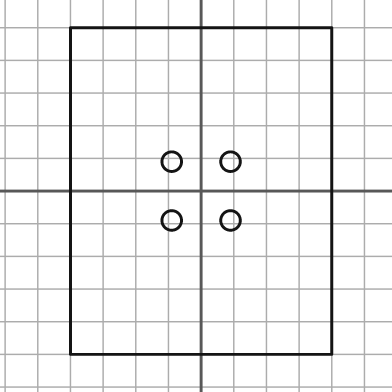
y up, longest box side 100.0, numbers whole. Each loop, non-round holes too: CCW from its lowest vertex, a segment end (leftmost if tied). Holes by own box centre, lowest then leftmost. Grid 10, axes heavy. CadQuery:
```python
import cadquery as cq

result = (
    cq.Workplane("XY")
    .moveTo(-40.0, -50.0)
    .lineTo(40.0, -50.0)
    .lineTo(40.0, 50.0)
    .lineTo(-40.0, 50.0)
    .close()
    .moveTo(-9.0, -9.0)
    .circle(3.0)
    .moveTo(9.0, -9.0)
    .circle(3.0)
    .moveTo(-9.0, 9.0)
    .circle(3.0)
    .moveTo(9.0, 9.0)
    .circle(3.0)
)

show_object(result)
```